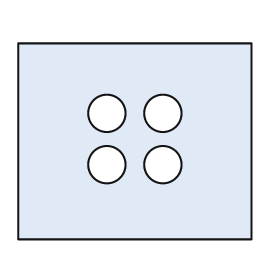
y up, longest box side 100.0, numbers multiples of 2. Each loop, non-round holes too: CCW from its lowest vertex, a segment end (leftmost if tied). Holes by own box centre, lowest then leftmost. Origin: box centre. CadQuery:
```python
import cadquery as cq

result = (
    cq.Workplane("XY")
    .moveTo(-50.0, -42.0)
    .lineTo(50.0, -42.0)
    .lineTo(50.0, 42.0)
    .lineTo(-50.0, 42.0)
    .close()
    .moveTo(-12.0, -10.0)
    .circle(8.0)
    .moveTo(12.0, -10.0)
    .circle(8.0)
    .moveTo(-12.0, 12.0)
    .circle(8.0)
    .moveTo(12.0, 12.0)
    .circle(8.0)
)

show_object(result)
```